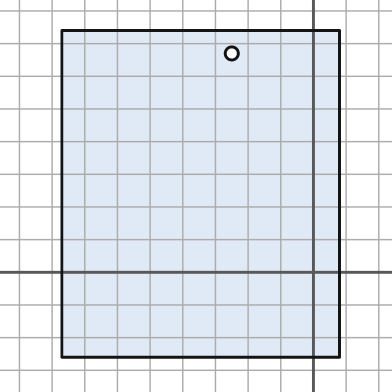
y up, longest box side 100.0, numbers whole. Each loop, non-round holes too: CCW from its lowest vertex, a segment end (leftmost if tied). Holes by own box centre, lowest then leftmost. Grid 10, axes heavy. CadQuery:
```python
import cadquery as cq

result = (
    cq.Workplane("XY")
    .moveTo(-77.0, -26.0)
    .lineTo(8.0, -26.0)
    .lineTo(8.0, 74.0)
    .lineTo(-77.0, 74.0)
    .close()
    .moveTo(-25.0, 67.0)
    .circle(2.0)
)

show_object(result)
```